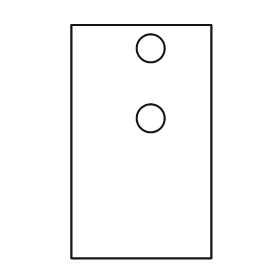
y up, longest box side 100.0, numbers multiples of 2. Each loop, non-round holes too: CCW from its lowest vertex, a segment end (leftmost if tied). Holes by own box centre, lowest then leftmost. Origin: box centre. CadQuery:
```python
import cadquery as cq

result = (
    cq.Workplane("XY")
    .moveTo(-30.0, -50.0)
    .lineTo(30.0, -50.0)
    .lineTo(30.0, 50.0)
    .lineTo(-30.0, 50.0)
    .close()
    .moveTo(4.0, 10.0)
    .circle(6.0)
    .moveTo(4.0, 40.0)
    .circle(6.0)
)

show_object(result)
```